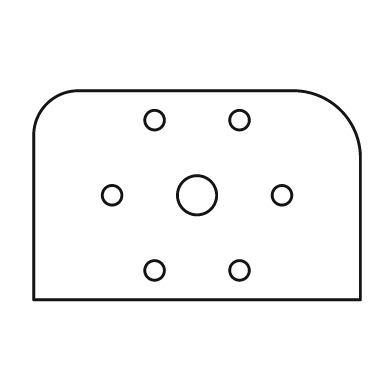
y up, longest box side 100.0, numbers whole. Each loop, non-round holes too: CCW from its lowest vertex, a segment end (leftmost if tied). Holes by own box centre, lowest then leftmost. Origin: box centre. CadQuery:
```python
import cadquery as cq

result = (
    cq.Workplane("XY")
    .moveTo(-50.0, -32.0)
    .lineTo(50.0, -32.0)
    .lineTo(50.0, 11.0)
    .threePointArc((44.0, 26.0), (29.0, 32.0))
    .lineTo(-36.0, 32.0)
    .threePointArc((-46.0, 28.0), (-50.0, 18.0))
    .close()
    .moveTo(-13.0, -23.0)
    .circle(3.0)
    .moveTo(13.0, -23.0)
    .circle(3.0)
    .moveTo(-26.0, 0.0)
    .circle(3.0)
    .moveTo(0.0, 0.0)
    .circle(6.0)
    .moveTo(26.0, 0.0)
    .circle(3.0)
    .moveTo(-13.0, 23.0)
    .circle(3.0)
    .moveTo(13.0, 23.0)
    .circle(3.0)
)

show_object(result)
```